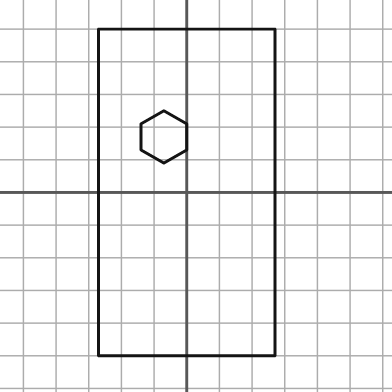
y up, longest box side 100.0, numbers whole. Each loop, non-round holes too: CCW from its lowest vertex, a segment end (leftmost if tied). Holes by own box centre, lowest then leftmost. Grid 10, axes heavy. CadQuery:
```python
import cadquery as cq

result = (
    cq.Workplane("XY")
    .moveTo(-27.0, -50.0)
    .lineTo(27.0, -50.0)
    .lineTo(27.0, 50.0)
    .lineTo(-27.0, 50.0)
    .close()
    .moveTo(-7.0, 9.0)
    .lineTo(0.0, 13.0)
    .lineTo(0.0, 21.0)
    .lineTo(-7.0, 25.0)
    .lineTo(-14.0, 21.0)
    .lineTo(-14.0, 13.0)
    .close()
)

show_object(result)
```